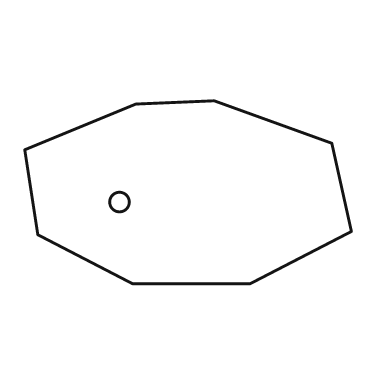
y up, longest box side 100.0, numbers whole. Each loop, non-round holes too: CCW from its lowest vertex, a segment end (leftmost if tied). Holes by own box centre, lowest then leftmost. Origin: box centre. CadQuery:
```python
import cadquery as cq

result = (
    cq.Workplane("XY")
    .moveTo(-17.0, -28.0)
    .lineTo(19.0, -28.0)
    .lineTo(50.0, -12.0)
    .lineTo(44.0, 15.0)
    .lineTo(8.0, 28.0)
    .lineTo(-16.0, 27.0)
    .lineTo(-50.0, 13.0)
    .lineTo(-46.0, -13.0)
    .close()
    .moveTo(-21.0, -3.0)
    .circle(3.0)
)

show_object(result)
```